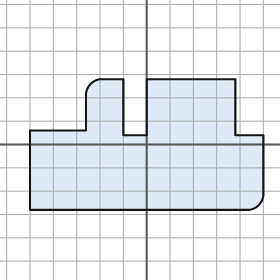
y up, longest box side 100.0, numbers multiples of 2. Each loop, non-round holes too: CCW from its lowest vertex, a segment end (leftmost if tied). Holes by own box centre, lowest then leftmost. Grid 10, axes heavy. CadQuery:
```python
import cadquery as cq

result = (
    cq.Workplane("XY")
    .moveTo(-50.0, -28.0)
    .lineTo(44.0, -28.0)
    .threePointArc((48.0, -26.0), (50.0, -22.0))
    .lineTo(50.0, 4.0)
    .lineTo(38.0, 4.0)
    .lineTo(38.0, 28.0)
    .lineTo(0.0, 28.0)
    .lineTo(0.0, 4.0)
    .lineTo(-10.0, 4.0)
    .lineTo(-10.0, 28.0)
    .lineTo(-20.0, 28.0)
    .threePointArc((-24.0, 26.0), (-26.0, 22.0))
    .lineTo(-26.0, 6.0)
    .lineTo(-50.0, 6.0)
    .close()
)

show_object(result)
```